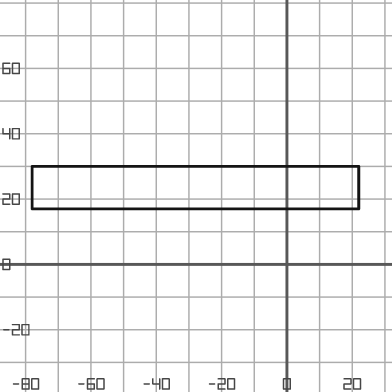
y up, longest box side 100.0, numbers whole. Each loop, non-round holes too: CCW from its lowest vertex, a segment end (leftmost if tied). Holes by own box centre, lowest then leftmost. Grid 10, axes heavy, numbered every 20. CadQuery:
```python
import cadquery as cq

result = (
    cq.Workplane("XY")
    .moveTo(-78.0, 17.0)
    .lineTo(22.0, 17.0)
    .lineTo(22.0, 30.0)
    .lineTo(-78.0, 30.0)
    .close()
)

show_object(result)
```